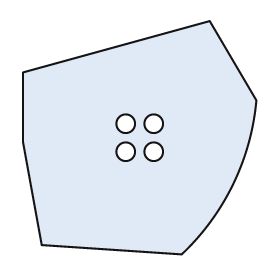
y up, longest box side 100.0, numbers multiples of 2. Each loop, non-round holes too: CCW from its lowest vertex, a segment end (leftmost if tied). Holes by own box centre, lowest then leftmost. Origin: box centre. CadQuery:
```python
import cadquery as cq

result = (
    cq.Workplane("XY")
    .moveTo(18.0, -50.0)
    .threePointArc((40.0, -20.0), (50.0, 16.0))
    .lineTo(30.0, 50.0)
    .lineTo(-50.0, 28.0)
    .lineTo(-50.0, -2.0)
    .lineTo(-42.0, -46.0)
    .close()
    .moveTo(-6.0, -6.0)
    .circle(4.0)
    .moveTo(6.0, -6.0)
    .circle(4.0)
    .moveTo(-6.0, 6.0)
    .circle(4.0)
    .moveTo(6.0, 6.0)
    .circle(4.0)
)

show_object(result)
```